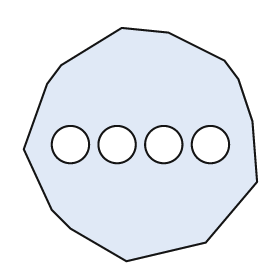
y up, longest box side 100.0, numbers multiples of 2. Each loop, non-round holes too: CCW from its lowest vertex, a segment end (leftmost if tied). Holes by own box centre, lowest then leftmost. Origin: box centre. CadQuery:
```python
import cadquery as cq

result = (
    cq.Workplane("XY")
    .moveTo(-6.0, -50.0)
    .lineTo(28.0, -42.0)
    .lineTo(50.0, -16.0)
    .lineTo(48.0, 10.0)
    .lineTo(42.0, 28.0)
    .lineTo(36.0, 36.0)
    .lineTo(12.0, 48.0)
    .lineTo(-8.0, 50.0)
    .lineTo(-34.0, 34.0)
    .lineTo(-40.0, 26.0)
    .lineTo(-50.0, -2.0)
    .lineTo(-38.0, -28.0)
    .lineTo(-30.0, -36.0)
    .close()
    .moveTo(-30.0, 0.0)
    .circle(8.0)
    .moveTo(-10.0, 0.0)
    .circle(8.0)
    .moveTo(10.0, 0.0)
    .circle(8.0)
    .moveTo(30.0, 0.0)
    .circle(8.0)
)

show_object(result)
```